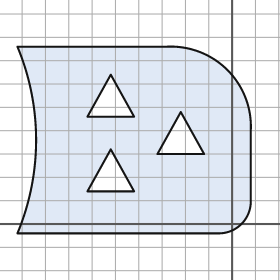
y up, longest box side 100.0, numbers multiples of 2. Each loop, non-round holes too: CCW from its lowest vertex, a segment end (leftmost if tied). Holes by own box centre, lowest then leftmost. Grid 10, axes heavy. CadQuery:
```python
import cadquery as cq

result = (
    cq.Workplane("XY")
    .moveTo(-92.0, -4.0)
    .lineTo(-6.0, -4.0)
    .threePointArc((4.0, 0.0), (8.0, 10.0))
    .lineTo(8.0, 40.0)
    .threePointArc((-2.0, 66.0), (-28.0, 76.0))
    .lineTo(-92.0, 76.0)
    .threePointArc((-84.0, 36.0), (-92.0, -4.0))
    .close()
    .moveTo(-62.0, 14.0)
    .lineTo(-42.0, 14.0)
    .lineTo(-52.0, 32.0)
    .close()
    .moveTo(-32.0, 30.0)
    .lineTo(-12.0, 30.0)
    .lineTo(-22.0, 48.0)
    .close()
    .moveTo(-62.0, 46.0)
    .lineTo(-42.0, 46.0)
    .lineTo(-52.0, 64.0)
    .close()
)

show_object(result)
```